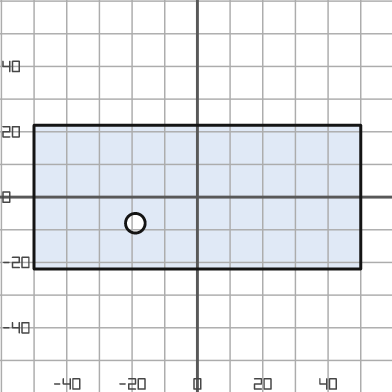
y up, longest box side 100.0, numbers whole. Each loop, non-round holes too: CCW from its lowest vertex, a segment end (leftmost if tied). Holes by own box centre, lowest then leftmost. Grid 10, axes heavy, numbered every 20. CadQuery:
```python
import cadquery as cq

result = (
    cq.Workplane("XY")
    .moveTo(-50.0, -22.0)
    .lineTo(50.0, -22.0)
    .lineTo(50.0, 22.0)
    .lineTo(-50.0, 22.0)
    .close()
    .moveTo(-19.0, -8.0)
    .circle(3.0)
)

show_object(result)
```